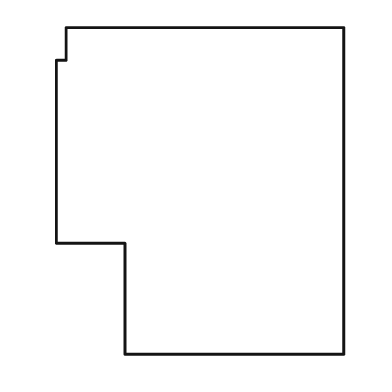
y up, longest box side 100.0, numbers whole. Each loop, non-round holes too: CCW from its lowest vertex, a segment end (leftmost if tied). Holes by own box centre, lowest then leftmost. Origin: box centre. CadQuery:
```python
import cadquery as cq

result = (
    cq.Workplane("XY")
    .moveTo(-23.0, -50.0)
    .lineTo(44.0, -50.0)
    .lineTo(44.0, 50.0)
    .lineTo(-41.0, 50.0)
    .lineTo(-41.0, 40.0)
    .lineTo(-44.0, 40.0)
    .lineTo(-44.0, -16.0)
    .lineTo(-23.0, -16.0)
    .close()
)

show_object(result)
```